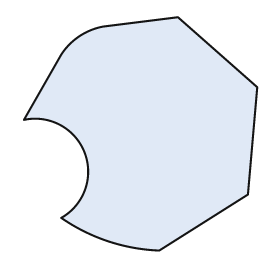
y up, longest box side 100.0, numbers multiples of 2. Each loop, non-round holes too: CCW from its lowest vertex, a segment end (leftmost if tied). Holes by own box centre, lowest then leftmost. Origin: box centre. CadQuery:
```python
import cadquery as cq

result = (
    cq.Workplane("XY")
    .moveTo(8.0, -50.0)
    .lineTo(46.0, -26.0)
    .lineTo(50.0, 20.0)
    .lineTo(16.0, 50.0)
    .lineTo(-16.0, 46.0)
    .threePointArc((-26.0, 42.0), (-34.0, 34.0))
    .lineTo(-50.0, 6.0)
    .threePointArc((-24.0, -8.0), (-34.0, -36.0))
    .threePointArc((-14.0, -46.0), (8.0, -50.0))
    .close()
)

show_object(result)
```